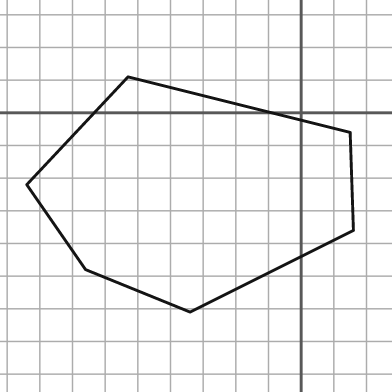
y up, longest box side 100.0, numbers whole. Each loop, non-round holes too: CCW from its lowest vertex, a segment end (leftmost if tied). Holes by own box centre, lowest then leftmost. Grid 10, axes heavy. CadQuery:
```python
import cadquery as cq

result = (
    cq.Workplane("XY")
    .moveTo(-34.0, -61.0)
    .lineTo(16.0, -36.0)
    .lineTo(15.0, -6.0)
    .lineTo(-53.0, 11.0)
    .lineTo(-84.0, -22.0)
    .lineTo(-66.0, -48.0)
    .close()
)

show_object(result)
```